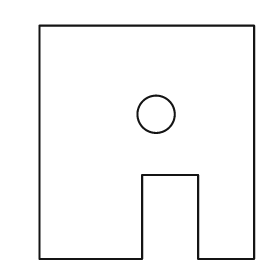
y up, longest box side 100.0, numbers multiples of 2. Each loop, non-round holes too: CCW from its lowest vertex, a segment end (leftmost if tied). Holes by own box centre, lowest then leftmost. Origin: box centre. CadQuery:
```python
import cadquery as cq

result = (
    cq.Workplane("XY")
    .moveTo(-46.0, -50.0)
    .lineTo(-2.0, -50.0)
    .lineTo(-2.0, -14.0)
    .lineTo(22.0, -14.0)
    .lineTo(22.0, -50.0)
    .lineTo(46.0, -50.0)
    .lineTo(46.0, 50.0)
    .lineTo(-46.0, 50.0)
    .close()
    .moveTo(4.0, 12.0)
    .circle(8.0)
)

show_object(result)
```